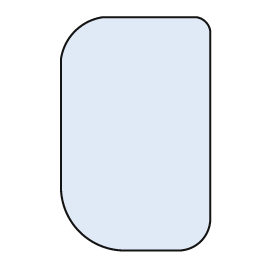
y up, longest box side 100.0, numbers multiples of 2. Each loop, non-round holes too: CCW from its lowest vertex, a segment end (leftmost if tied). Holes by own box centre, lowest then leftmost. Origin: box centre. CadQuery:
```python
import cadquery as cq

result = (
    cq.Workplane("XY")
    .moveTo(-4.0, -50.0)
    .lineTo(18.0, -50.0)
    .threePointArc((28.0, -46.0), (32.0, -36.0))
    .lineTo(32.0, 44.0)
    .threePointArc((30.0, 48.0), (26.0, 50.0))
    .lineTo(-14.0, 50.0)
    .threePointArc((-26.0, 44.0), (-32.0, 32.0))
    .lineTo(-32.0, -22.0)
    .threePointArc((-24.0, -42.0), (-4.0, -50.0))
    .close()
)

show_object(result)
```